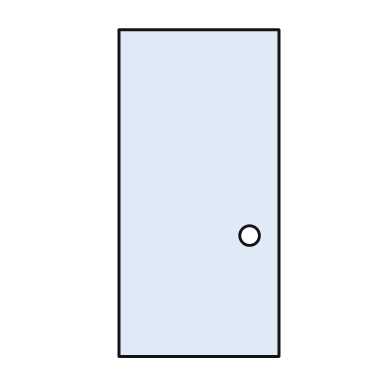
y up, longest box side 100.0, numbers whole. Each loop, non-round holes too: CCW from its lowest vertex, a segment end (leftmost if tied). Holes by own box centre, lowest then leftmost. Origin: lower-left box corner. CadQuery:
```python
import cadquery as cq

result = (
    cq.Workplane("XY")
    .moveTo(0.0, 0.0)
    .lineTo(49.0, 0.0)
    .lineTo(49.0, 100.0)
    .lineTo(0.0, 100.0)
    .close()
    .moveTo(40.0, 37.0)
    .circle(3.0)
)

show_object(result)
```